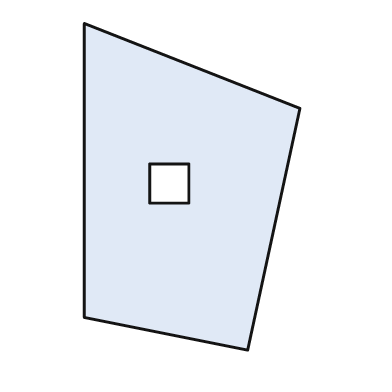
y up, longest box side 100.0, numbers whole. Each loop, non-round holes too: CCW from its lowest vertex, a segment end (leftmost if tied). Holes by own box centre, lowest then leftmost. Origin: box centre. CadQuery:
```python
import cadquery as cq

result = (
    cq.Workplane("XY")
    .moveTo(17.0, -50.0)
    .lineTo(33.0, 24.0)
    .lineTo(-33.0, 50.0)
    .lineTo(-33.0, -40.0)
    .close()
    .moveTo(-13.0, -5.0)
    .lineTo(-1.0, -5.0)
    .lineTo(-1.0, 7.0)
    .lineTo(-13.0, 7.0)
    .close()
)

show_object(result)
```